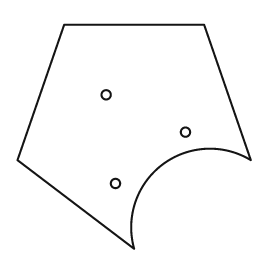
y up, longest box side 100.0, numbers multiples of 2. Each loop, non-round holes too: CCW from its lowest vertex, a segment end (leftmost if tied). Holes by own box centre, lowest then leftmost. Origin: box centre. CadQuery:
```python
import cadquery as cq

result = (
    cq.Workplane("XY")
    .moveTo(0.0, -48.0)
    .threePointArc((12.0, -12.0), (50.0, -10.0))
    .lineTo(30.0, 48.0)
    .lineTo(-30.0, 48.0)
    .lineTo(-50.0, -10.0)
    .close()
    .moveTo(-8.0, -20.0)
    .circle(2.0)
    .moveTo(22.0, 2.0)
    .circle(2.0)
    .moveTo(-12.0, 18.0)
    .circle(2.0)
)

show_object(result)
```